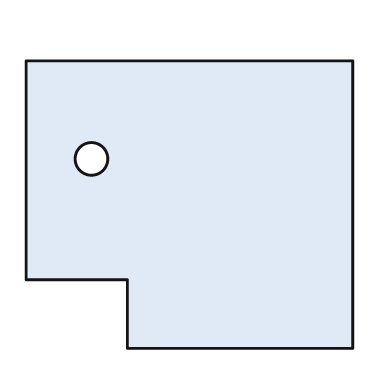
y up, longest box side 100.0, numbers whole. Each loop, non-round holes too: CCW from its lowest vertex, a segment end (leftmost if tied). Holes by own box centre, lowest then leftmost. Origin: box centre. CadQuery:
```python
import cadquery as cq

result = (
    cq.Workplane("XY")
    .moveTo(-19.0, -44.0)
    .lineTo(50.0, -44.0)
    .lineTo(50.0, 44.0)
    .lineTo(-50.0, 44.0)
    .lineTo(-50.0, -23.0)
    .lineTo(-19.0, -23.0)
    .close()
    .moveTo(-30.0, 14.0)
    .circle(5.0)
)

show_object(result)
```